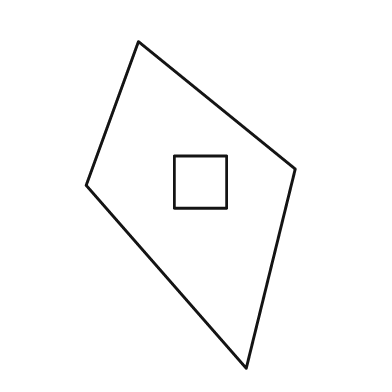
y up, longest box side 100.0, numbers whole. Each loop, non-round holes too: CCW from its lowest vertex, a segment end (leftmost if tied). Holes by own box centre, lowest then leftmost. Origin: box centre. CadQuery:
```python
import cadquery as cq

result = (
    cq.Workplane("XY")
    .moveTo(17.0, -50.0)
    .lineTo(32.0, 11.0)
    .lineTo(-16.0, 50.0)
    .lineTo(-32.0, 6.0)
    .close()
    .moveTo(-5.0, -1.0)
    .lineTo(11.0, -1.0)
    .lineTo(11.0, 15.0)
    .lineTo(-5.0, 15.0)
    .close()
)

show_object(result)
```